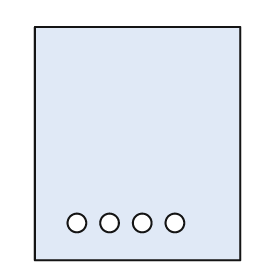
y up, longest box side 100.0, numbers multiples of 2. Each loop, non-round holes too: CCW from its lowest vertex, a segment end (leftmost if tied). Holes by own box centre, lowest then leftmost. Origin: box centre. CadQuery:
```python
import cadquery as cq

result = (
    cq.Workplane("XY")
    .moveTo(-44.0, -50.0)
    .lineTo(44.0, -50.0)
    .lineTo(44.0, 50.0)
    .lineTo(-44.0, 50.0)
    .close()
    .moveTo(-26.0, -34.0)
    .circle(4.0)
    .moveTo(-12.0, -34.0)
    .circle(4.0)
    .moveTo(2.0, -34.0)
    .circle(4.0)
    .moveTo(16.0, -34.0)
    .circle(4.0)
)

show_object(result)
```